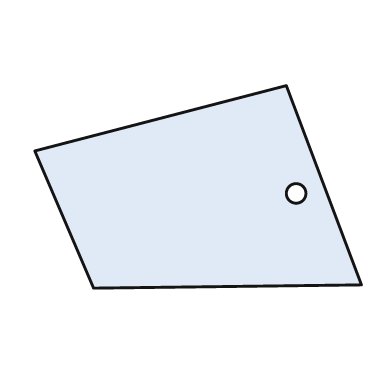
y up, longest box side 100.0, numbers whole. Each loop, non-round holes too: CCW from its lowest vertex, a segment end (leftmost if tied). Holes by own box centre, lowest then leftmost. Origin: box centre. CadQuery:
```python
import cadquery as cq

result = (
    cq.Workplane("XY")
    .moveTo(-32.0, -31.0)
    .lineTo(50.0, -30.0)
    .lineTo(27.0, 31.0)
    .lineTo(-50.0, 11.0)
    .close()
    .moveTo(30.0, -2.0)
    .circle(3.0)
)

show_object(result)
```